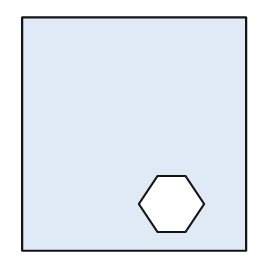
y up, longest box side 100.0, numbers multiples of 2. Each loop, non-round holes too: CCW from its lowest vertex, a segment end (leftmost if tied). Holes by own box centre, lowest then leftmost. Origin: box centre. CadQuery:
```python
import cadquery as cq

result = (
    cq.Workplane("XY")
    .moveTo(-48.0, -50.0)
    .lineTo(48.0, -50.0)
    .lineTo(48.0, 50.0)
    .lineTo(-48.0, 50.0)
    .close()
    .moveTo(10.0, -42.0)
    .lineTo(22.0, -42.0)
    .lineTo(30.0, -30.0)
    .lineTo(22.0, -18.0)
    .lineTo(10.0, -18.0)
    .lineTo(2.0, -30.0)
    .close()
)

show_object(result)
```